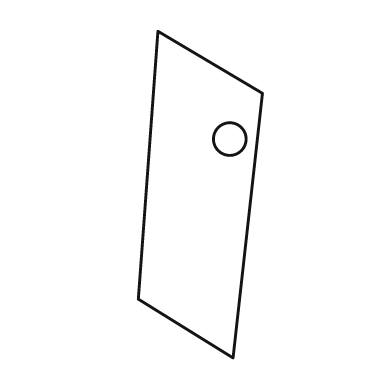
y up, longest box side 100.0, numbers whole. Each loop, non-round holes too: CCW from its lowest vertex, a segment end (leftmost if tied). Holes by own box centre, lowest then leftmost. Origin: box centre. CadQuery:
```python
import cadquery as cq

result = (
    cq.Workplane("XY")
    .moveTo(10.0, -50.0)
    .lineTo(19.0, 31.0)
    .lineTo(-13.0, 50.0)
    .lineTo(-19.0, -32.0)
    .close()
    .moveTo(9.0, 17.0)
    .circle(5.0)
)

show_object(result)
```